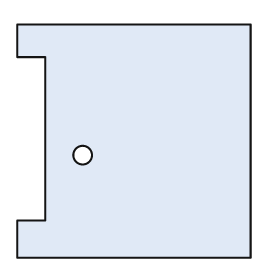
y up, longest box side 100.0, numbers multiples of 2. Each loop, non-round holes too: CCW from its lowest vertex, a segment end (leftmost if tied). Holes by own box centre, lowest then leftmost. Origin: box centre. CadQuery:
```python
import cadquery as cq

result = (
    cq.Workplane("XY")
    .moveTo(-50.0, -50.0)
    .lineTo(50.0, -50.0)
    .lineTo(50.0, 50.0)
    .lineTo(-50.0, 50.0)
    .lineTo(-50.0, 36.0)
    .lineTo(-38.0, 36.0)
    .lineTo(-38.0, -34.0)
    .lineTo(-50.0, -34.0)
    .close()
    .moveTo(-22.0, -6.0)
    .circle(4.0)
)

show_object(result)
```